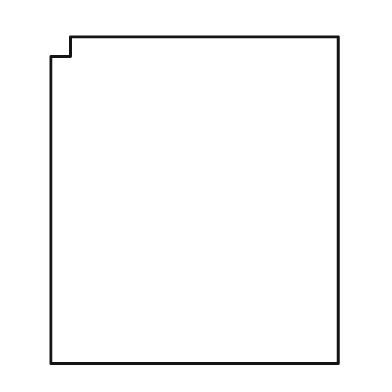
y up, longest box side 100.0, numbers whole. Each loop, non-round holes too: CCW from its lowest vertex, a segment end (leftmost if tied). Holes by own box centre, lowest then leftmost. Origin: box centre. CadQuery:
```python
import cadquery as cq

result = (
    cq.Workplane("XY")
    .moveTo(-44.0, -50.0)
    .lineTo(44.0, -50.0)
    .lineTo(44.0, 50.0)
    .lineTo(-38.0, 50.0)
    .lineTo(-38.0, 44.0)
    .lineTo(-44.0, 44.0)
    .close()
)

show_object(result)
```